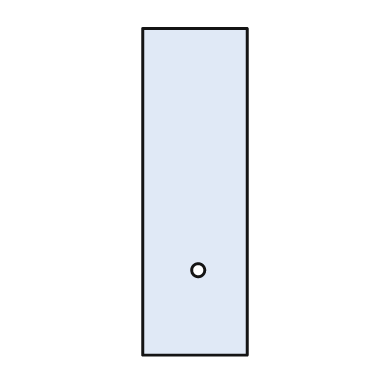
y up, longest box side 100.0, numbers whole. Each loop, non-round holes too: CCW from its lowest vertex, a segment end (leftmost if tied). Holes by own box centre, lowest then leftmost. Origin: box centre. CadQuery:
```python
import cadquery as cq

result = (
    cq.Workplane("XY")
    .moveTo(-16.0, -50.0)
    .lineTo(16.0, -50.0)
    .lineTo(16.0, 50.0)
    .lineTo(-16.0, 50.0)
    .close()
    .moveTo(1.0, -24.0)
    .circle(2.0)
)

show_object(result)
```